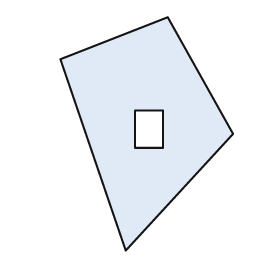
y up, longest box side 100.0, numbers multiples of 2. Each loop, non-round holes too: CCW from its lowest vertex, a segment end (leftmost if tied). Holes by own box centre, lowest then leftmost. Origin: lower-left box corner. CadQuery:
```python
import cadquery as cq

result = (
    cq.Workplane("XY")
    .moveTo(28.0, 0.0)
    .lineTo(74.0, 50.0)
    .lineTo(46.0, 100.0)
    .lineTo(0.0, 82.0)
    .close()
    .moveTo(32.0, 44.0)
    .lineTo(44.0, 44.0)
    .lineTo(44.0, 60.0)
    .lineTo(32.0, 60.0)
    .close()
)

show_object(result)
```